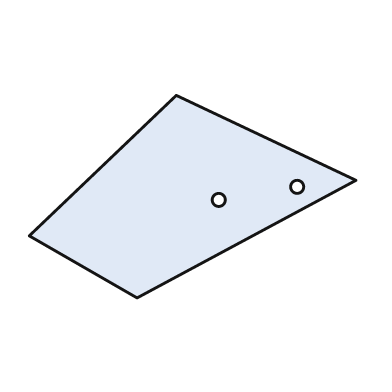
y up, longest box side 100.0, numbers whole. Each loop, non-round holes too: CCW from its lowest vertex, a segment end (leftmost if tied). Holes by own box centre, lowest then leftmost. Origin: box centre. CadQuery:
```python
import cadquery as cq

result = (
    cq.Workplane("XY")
    .moveTo(-17.0, -31.0)
    .lineTo(50.0, 5.0)
    .lineTo(-5.0, 31.0)
    .lineTo(-50.0, -12.0)
    .close()
    .moveTo(8.0, -1.0)
    .circle(2.0)
    .moveTo(32.0, 3.0)
    .circle(2.0)
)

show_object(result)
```